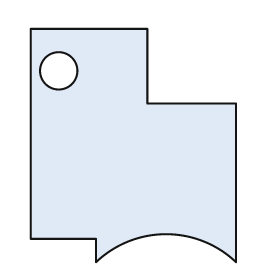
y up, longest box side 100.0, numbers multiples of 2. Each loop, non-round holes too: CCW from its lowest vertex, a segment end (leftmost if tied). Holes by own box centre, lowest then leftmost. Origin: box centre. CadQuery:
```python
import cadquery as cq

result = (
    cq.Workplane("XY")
    .moveTo(-16.0, -50.0)
    .threePointArc((14.0, -38.0), (44.0, -50.0))
    .lineTo(44.0, 18.0)
    .lineTo(6.0, 18.0)
    .lineTo(6.0, 50.0)
    .lineTo(-44.0, 50.0)
    .lineTo(-44.0, -40.0)
    .lineTo(-16.0, -40.0)
    .close()
    .moveTo(-32.0, 32.0)
    .circle(8.0)
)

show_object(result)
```